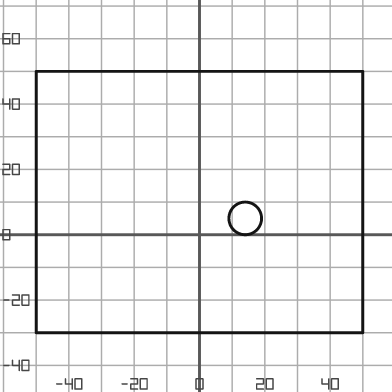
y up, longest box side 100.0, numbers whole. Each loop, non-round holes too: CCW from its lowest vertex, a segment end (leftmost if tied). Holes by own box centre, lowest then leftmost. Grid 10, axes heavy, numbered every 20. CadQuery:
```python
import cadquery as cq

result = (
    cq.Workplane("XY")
    .moveTo(-50.0, -30.0)
    .lineTo(50.0, -30.0)
    .lineTo(50.0, 50.0)
    .lineTo(-50.0, 50.0)
    .close()
    .moveTo(14.0, 5.0)
    .circle(5.0)
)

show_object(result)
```